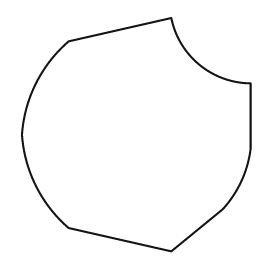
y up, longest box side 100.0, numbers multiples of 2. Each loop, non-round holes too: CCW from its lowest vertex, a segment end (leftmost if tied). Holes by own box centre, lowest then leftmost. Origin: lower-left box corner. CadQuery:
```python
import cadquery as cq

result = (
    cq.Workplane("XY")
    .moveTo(64.0, 0.0)
    .lineTo(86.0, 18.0)
    .threePointArc((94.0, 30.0), (98.0, 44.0))
    .lineTo(98.0, 72.0)
    .threePointArc((76.0, 80.0), (64.0, 100.0))
    .lineTo(20.0, 90.0)
    .threePointArc((6.0, 72.0), (0.0, 50.0))
    .threePointArc((6.0, 28.0), (20.0, 10.0))
    .close()
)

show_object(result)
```